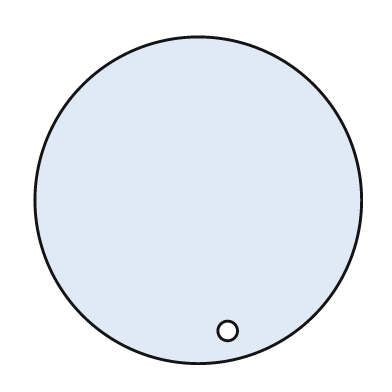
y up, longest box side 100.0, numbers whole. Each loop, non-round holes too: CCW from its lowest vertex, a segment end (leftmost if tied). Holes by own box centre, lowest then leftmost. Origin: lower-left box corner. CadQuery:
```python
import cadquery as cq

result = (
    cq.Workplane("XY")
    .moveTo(50.0, 50.0)
    .circle(50.0)
    .moveTo(59.0, 10.0)
    .circle(3.0)
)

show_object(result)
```